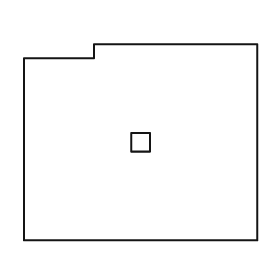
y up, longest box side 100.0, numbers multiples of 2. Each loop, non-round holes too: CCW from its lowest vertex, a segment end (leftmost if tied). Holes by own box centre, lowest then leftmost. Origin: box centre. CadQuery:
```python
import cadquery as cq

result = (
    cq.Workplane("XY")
    .moveTo(-50.0, -42.0)
    .lineTo(50.0, -42.0)
    .lineTo(50.0, 42.0)
    .lineTo(-20.0, 42.0)
    .lineTo(-20.0, 36.0)
    .lineTo(-50.0, 36.0)
    .close()
    .moveTo(-4.0, -4.0)
    .lineTo(4.0, -4.0)
    .lineTo(4.0, 4.0)
    .lineTo(-4.0, 4.0)
    .close()
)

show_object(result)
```